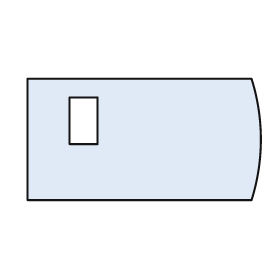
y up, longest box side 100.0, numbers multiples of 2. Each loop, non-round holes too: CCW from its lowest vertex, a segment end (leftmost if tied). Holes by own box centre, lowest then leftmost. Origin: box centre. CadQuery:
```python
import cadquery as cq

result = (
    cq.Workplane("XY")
    .moveTo(-50.0, -26.0)
    .lineTo(46.0, -26.0)
    .threePointArc((50.0, 0.0), (46.0, 26.0))
    .lineTo(-50.0, 26.0)
    .close()
    .moveTo(-32.0, -2.0)
    .lineTo(-20.0, -2.0)
    .lineTo(-20.0, 18.0)
    .lineTo(-32.0, 18.0)
    .close()
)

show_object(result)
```